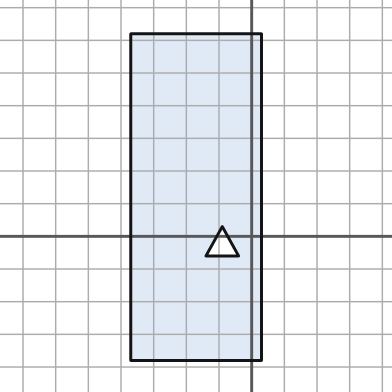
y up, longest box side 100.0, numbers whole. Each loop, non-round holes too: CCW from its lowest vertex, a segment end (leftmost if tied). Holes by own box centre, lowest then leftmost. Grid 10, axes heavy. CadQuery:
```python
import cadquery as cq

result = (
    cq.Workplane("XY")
    .moveTo(-37.0, -38.0)
    .lineTo(3.0, -38.0)
    .lineTo(3.0, 62.0)
    .lineTo(-37.0, 62.0)
    .close()
    .moveTo(-14.0, -6.0)
    .lineTo(-4.0, -6.0)
    .lineTo(-9.0, 3.0)
    .close()
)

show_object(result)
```